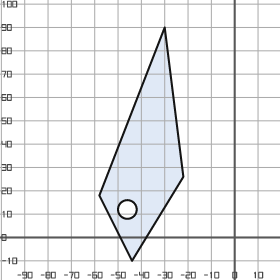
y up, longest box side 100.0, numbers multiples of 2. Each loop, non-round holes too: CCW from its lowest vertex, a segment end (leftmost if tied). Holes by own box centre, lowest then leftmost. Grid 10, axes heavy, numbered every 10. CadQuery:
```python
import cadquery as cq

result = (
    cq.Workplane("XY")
    .moveTo(-44.0, -10.0)
    .lineTo(-22.0, 26.0)
    .lineTo(-30.0, 90.0)
    .lineTo(-58.0, 18.0)
    .close()
    .moveTo(-46.0, 12.0)
    .circle(4.0)
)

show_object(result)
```